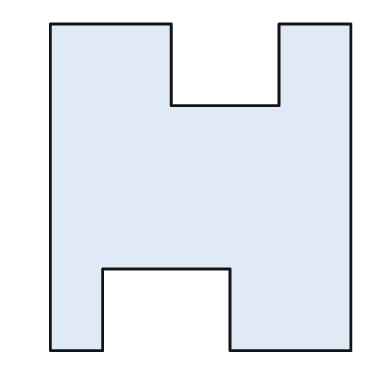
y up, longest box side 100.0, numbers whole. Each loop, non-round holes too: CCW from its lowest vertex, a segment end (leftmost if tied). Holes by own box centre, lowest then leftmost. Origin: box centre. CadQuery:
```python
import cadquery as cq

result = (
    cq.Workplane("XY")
    .moveTo(-46.0, -50.0)
    .lineTo(-30.0, -50.0)
    .lineTo(-30.0, -25.0)
    .lineTo(9.0, -25.0)
    .lineTo(9.0, -50.0)
    .lineTo(46.0, -50.0)
    .lineTo(46.0, 50.0)
    .lineTo(24.0, 50.0)
    .lineTo(24.0, 25.0)
    .lineTo(-9.0, 25.0)
    .lineTo(-9.0, 50.0)
    .lineTo(-46.0, 50.0)
    .close()
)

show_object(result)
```